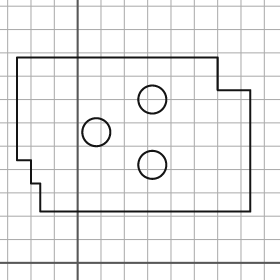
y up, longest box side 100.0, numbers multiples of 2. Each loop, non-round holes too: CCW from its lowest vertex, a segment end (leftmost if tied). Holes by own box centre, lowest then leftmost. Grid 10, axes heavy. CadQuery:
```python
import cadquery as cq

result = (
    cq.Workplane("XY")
    .moveTo(-16.0, 22.0)
    .lineTo(74.0, 22.0)
    .lineTo(74.0, 74.0)
    .lineTo(60.0, 74.0)
    .lineTo(60.0, 88.0)
    .lineTo(-26.0, 88.0)
    .lineTo(-26.0, 44.0)
    .lineTo(-20.0, 44.0)
    .lineTo(-20.0, 34.0)
    .lineTo(-16.0, 34.0)
    .close()
    .moveTo(32.0, 42.0)
    .circle(6.0)
    .moveTo(8.0, 56.0)
    .circle(6.0)
    .moveTo(32.0, 70.0)
    .circle(6.0)
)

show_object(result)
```